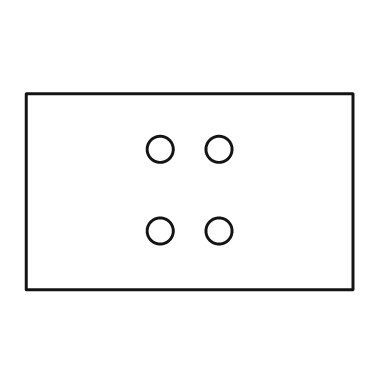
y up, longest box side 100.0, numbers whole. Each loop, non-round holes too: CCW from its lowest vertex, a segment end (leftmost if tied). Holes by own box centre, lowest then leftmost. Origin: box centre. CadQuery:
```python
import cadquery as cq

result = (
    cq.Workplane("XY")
    .moveTo(-50.0, -30.0)
    .lineTo(50.0, -30.0)
    .lineTo(50.0, 30.0)
    .lineTo(-50.0, 30.0)
    .close()
    .moveTo(-9.0, -12.0)
    .circle(4.0)
    .moveTo(9.0, -12.0)
    .circle(4.0)
    .moveTo(-9.0, 13.0)
    .circle(4.0)
    .moveTo(9.0, 13.0)
    .circle(4.0)
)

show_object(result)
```